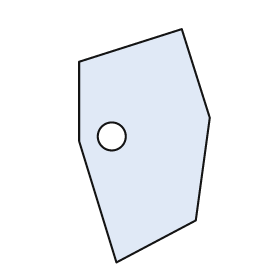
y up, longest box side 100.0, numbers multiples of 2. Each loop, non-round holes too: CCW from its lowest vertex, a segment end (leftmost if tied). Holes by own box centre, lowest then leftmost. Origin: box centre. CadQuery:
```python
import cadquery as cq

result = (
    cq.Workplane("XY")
    .moveTo(-12.0, -50.0)
    .lineTo(22.0, -32.0)
    .lineTo(28.0, 12.0)
    .lineTo(16.0, 50.0)
    .lineTo(-28.0, 36.0)
    .lineTo(-28.0, 2.0)
    .close()
    .moveTo(-14.0, 4.0)
    .circle(6.0)
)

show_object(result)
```